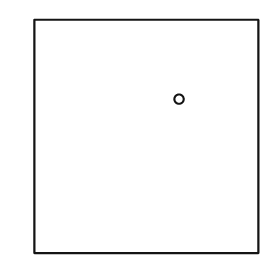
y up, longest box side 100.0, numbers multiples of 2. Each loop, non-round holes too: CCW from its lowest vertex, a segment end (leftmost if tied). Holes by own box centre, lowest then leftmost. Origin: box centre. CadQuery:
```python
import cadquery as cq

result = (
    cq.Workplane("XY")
    .moveTo(-48.0, -50.0)
    .lineTo(48.0, -50.0)
    .lineTo(48.0, 50.0)
    .lineTo(-48.0, 50.0)
    .close()
    .moveTo(14.0, 16.0)
    .circle(2.0)
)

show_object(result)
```